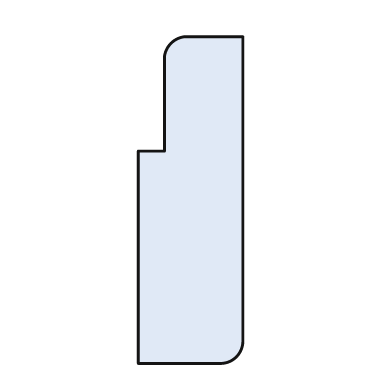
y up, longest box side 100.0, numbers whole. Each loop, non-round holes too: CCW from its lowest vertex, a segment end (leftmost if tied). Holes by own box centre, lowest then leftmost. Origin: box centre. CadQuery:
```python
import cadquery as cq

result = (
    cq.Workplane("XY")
    .moveTo(-16.0, -50.0)
    .lineTo(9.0, -50.0)
    .threePointArc((14.0, -48.0), (16.0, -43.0))
    .lineTo(16.0, 50.0)
    .lineTo(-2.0, 50.0)
    .threePointArc((-6.0, 48.0), (-8.0, 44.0))
    .lineTo(-8.0, 15.0)
    .lineTo(-16.0, 15.0)
    .close()
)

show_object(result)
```